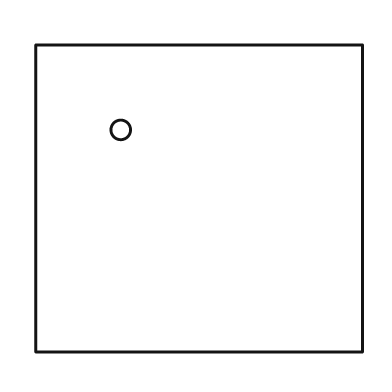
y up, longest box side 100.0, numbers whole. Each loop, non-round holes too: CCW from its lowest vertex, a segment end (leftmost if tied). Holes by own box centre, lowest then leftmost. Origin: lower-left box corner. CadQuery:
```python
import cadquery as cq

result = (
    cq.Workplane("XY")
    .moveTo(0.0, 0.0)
    .lineTo(100.0, 0.0)
    .lineTo(100.0, 94.0)
    .lineTo(0.0, 94.0)
    .close()
    .moveTo(26.0, 68.0)
    .circle(3.0)
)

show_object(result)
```